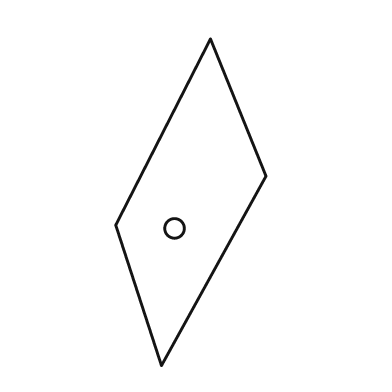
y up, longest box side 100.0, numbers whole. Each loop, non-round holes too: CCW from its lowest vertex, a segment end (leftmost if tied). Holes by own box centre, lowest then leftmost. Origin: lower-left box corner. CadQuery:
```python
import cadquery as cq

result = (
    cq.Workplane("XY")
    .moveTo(14.0, 0.0)
    .lineTo(46.0, 58.0)
    .lineTo(29.0, 100.0)
    .lineTo(0.0, 43.0)
    .close()
    .moveTo(18.0, 42.0)
    .circle(3.0)
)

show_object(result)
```